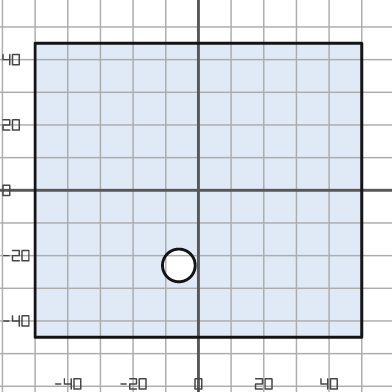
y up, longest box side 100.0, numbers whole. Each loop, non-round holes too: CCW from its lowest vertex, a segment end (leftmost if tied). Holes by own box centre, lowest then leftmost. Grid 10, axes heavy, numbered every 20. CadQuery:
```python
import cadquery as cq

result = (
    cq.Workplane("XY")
    .moveTo(-50.0, -45.0)
    .lineTo(50.0, -45.0)
    .lineTo(50.0, 45.0)
    .lineTo(-50.0, 45.0)
    .close()
    .moveTo(-6.0, -23.0)
    .circle(5.0)
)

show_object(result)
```